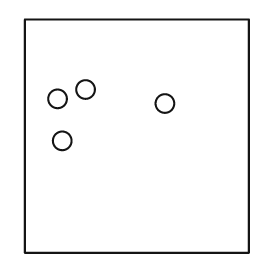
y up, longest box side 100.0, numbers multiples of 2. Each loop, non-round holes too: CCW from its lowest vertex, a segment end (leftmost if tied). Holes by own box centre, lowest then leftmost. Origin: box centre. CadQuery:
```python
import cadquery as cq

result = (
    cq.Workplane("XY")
    .moveTo(-48.0, -50.0)
    .lineTo(48.0, -50.0)
    .lineTo(48.0, 50.0)
    .lineTo(-48.0, 50.0)
    .close()
    .moveTo(-32.0, -2.0)
    .circle(4.0)
    .moveTo(12.0, 14.0)
    .circle(4.0)
    .moveTo(-34.0, 16.0)
    .circle(4.0)
    .moveTo(-22.0, 20.0)
    .circle(4.0)
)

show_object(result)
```